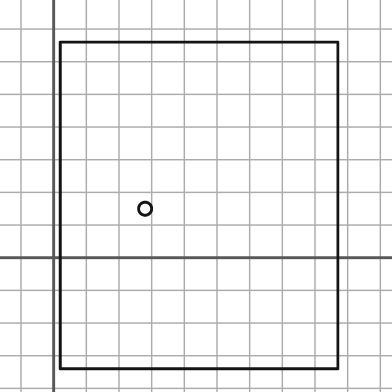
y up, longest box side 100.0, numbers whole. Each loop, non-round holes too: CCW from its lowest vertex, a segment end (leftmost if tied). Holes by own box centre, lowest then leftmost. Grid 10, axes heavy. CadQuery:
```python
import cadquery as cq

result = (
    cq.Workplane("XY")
    .moveTo(2.0, -34.0)
    .lineTo(87.0, -34.0)
    .lineTo(87.0, 66.0)
    .lineTo(2.0, 66.0)
    .close()
    .moveTo(28.0, 15.0)
    .circle(2.0)
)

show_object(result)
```